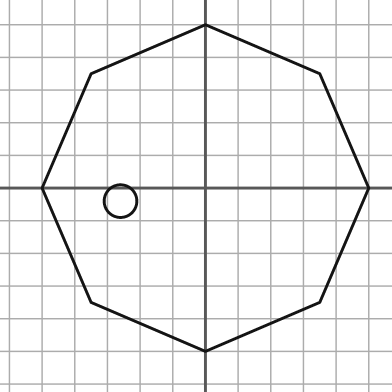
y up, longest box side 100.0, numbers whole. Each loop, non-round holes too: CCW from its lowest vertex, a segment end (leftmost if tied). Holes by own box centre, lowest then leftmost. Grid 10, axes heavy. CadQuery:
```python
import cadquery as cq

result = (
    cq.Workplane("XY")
    .moveTo(0.0, -50.0)
    .lineTo(35.0, -35.0)
    .lineTo(50.0, 0.0)
    .lineTo(35.0, 35.0)
    .lineTo(0.0, 50.0)
    .lineTo(-35.0, 35.0)
    .lineTo(-50.0, 0.0)
    .lineTo(-35.0, -35.0)
    .close()
    .moveTo(-26.0, -4.0)
    .circle(5.0)
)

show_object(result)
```